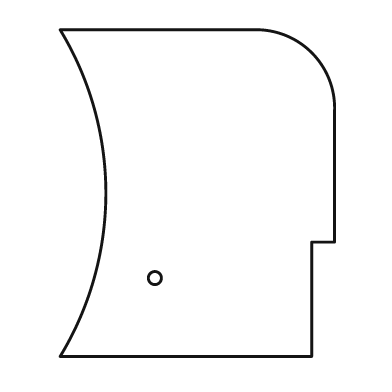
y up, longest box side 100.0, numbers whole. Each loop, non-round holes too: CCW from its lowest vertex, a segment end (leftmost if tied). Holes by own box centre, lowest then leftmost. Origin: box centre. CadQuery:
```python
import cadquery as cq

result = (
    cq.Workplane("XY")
    .moveTo(-42.0, -50.0)
    .lineTo(35.0, -50.0)
    .lineTo(35.0, -15.0)
    .lineTo(42.0, -15.0)
    .lineTo(42.0, 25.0)
    .threePointArc((35.0, 43.0), (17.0, 50.0))
    .lineTo(-42.0, 50.0)
    .threePointArc((-28.0, 0.0), (-42.0, -50.0))
    .close()
    .moveTo(-13.0, -26.0)
    .circle(2.0)
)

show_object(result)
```